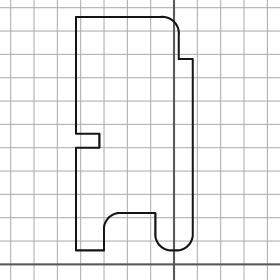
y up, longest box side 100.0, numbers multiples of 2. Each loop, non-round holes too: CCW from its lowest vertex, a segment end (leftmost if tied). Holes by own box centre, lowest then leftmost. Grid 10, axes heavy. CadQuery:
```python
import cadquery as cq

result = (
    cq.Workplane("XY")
    .moveTo(-42.0, 6.0)
    .lineTo(-30.0, 6.0)
    .lineTo(-30.0, 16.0)
    .threePointArc((-28.0, 20.0), (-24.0, 22.0))
    .lineTo(-8.0, 22.0)
    .lineTo(-8.0, 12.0)
    .threePointArc((-6.0, 8.0), (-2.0, 6.0))
    .lineTo(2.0, 6.0)
    .threePointArc((6.0, 8.0), (8.0, 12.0))
    .lineTo(8.0, 88.0)
    .lineTo(2.0, 88.0)
    .lineTo(2.0, 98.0)
    .threePointArc((0.0, 104.0), (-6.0, 106.0))
    .lineTo(-42.0, 106.0)
    .lineTo(-42.0, 56.0)
    .lineTo(-32.0, 56.0)
    .lineTo(-32.0, 50.0)
    .lineTo(-42.0, 50.0)
    .close()
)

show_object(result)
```